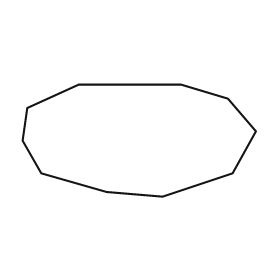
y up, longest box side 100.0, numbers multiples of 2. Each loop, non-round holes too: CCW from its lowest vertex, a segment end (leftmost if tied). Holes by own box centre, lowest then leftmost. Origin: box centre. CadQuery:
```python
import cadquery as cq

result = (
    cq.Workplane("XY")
    .moveTo(10.0, -24.0)
    .lineTo(40.0, -14.0)
    .lineTo(50.0, 4.0)
    .lineTo(38.0, 18.0)
    .lineTo(18.0, 24.0)
    .lineTo(-26.0, 24.0)
    .lineTo(-48.0, 14.0)
    .lineTo(-50.0, 0.0)
    .lineTo(-42.0, -14.0)
    .lineTo(-14.0, -22.0)
    .close()
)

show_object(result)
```